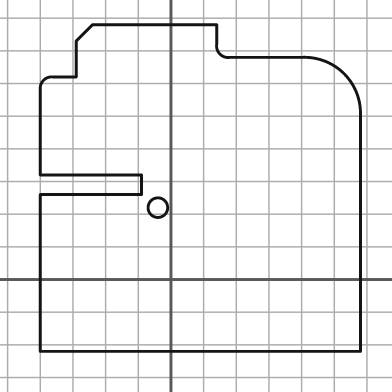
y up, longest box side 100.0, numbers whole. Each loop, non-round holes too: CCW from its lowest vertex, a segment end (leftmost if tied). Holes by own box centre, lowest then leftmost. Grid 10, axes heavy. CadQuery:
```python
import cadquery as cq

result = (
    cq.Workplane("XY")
    .moveTo(-40.0, -22.0)
    .lineTo(58.0, -22.0)
    .lineTo(58.0, 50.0)
    .threePointArc((53.0, 63.0), (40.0, 68.0))
    .lineTo(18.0, 68.0)
    .threePointArc((15.0, 69.0), (14.0, 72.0))
    .lineTo(14.0, 78.0)
    .lineTo(-24.0, 78.0)
    .lineTo(-29.0, 73.0)
    .lineTo(-29.0, 62.0)
    .lineTo(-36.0, 62.0)
    .threePointArc((-39.0, 61.0), (-40.0, 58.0))
    .lineTo(-40.0, 32.0)
    .lineTo(-9.0, 32.0)
    .lineTo(-9.0, 26.0)
    .lineTo(-40.0, 26.0)
    .close()
    .moveTo(-4.0, 22.0)
    .circle(3.0)
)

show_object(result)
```